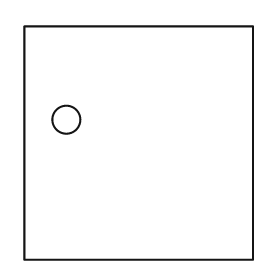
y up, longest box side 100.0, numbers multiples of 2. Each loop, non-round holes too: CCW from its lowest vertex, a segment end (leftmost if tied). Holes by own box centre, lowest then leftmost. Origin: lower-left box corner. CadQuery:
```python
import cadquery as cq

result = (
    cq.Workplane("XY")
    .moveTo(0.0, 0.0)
    .lineTo(98.0, 0.0)
    .lineTo(98.0, 100.0)
    .lineTo(0.0, 100.0)
    .close()
    .moveTo(18.0, 60.0)
    .circle(6.0)
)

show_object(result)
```